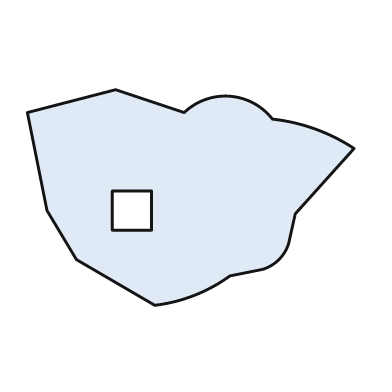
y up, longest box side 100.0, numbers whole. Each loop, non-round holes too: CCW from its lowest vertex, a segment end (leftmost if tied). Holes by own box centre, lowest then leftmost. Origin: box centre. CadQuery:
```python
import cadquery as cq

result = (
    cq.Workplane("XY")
    .moveTo(-11.0, -33.0)
    .threePointArc((1.0, -30.0), (12.0, -24.0))
    .lineTo(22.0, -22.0)
    .threePointArc((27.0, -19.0), (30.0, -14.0))
    .lineTo(32.0, -5.0)
    .lineTo(50.0, 15.0)
    .threePointArc((38.0, 21.0), (25.0, 24.0))
    .threePointArc((12.0, 31.0), (-2.0, 26.0))
    .lineTo(-23.0, 33.0)
    .lineTo(-50.0, 26.0)
    .lineTo(-44.0, -4.0)
    .lineTo(-35.0, -19.0)
    .close()
    .moveTo(-24.0, -10.0)
    .lineTo(-12.0, -10.0)
    .lineTo(-12.0, 2.0)
    .lineTo(-24.0, 2.0)
    .close()
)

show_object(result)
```